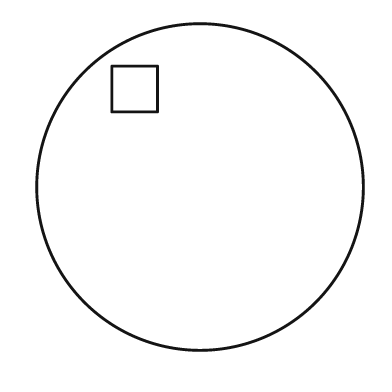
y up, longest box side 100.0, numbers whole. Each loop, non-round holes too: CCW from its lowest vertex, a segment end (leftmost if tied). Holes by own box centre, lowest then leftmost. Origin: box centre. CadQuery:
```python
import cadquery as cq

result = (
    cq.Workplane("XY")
    .moveTo(0.0, 0.0)
    .circle(50.0)
    .moveTo(-27.0, 23.0)
    .lineTo(-13.0, 23.0)
    .lineTo(-13.0, 37.0)
    .lineTo(-27.0, 37.0)
    .close()
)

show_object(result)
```